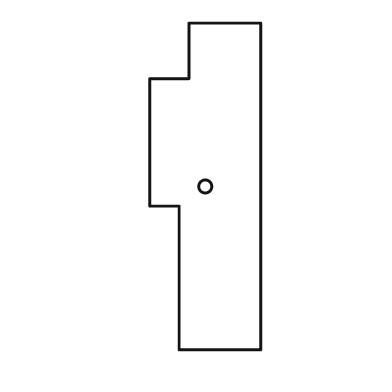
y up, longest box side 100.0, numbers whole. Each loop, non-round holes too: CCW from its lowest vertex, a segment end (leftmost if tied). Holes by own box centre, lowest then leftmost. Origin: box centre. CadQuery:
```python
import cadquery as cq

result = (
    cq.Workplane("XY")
    .moveTo(-8.0, -50.0)
    .lineTo(17.0, -50.0)
    .lineTo(17.0, 50.0)
    .lineTo(-5.0, 50.0)
    .lineTo(-5.0, 33.0)
    .lineTo(-17.0, 33.0)
    .lineTo(-17.0, -6.0)
    .lineTo(-8.0, -6.0)
    .close()
    .moveTo(0.0, 0.0)
    .circle(2.0)
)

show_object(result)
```